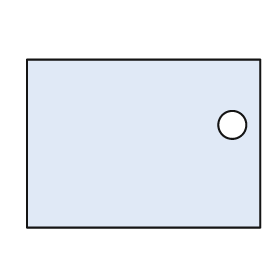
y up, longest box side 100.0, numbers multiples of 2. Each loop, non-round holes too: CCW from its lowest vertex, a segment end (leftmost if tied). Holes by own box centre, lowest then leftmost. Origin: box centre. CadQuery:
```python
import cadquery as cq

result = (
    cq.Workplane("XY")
    .moveTo(-50.0, -36.0)
    .lineTo(50.0, -36.0)
    .lineTo(50.0, 36.0)
    .lineTo(-50.0, 36.0)
    .close()
    .moveTo(38.0, 8.0)
    .circle(6.0)
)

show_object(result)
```